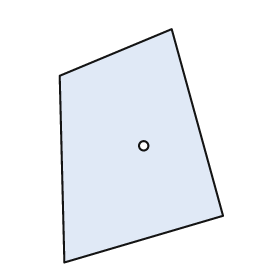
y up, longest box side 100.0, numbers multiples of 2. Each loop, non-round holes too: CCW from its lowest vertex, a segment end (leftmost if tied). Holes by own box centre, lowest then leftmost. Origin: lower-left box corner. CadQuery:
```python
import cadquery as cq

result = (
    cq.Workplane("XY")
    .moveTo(2.0, 0.0)
    .lineTo(70.0, 20.0)
    .lineTo(48.0, 100.0)
    .lineTo(0.0, 80.0)
    .close()
    .moveTo(36.0, 50.0)
    .circle(2.0)
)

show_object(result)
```